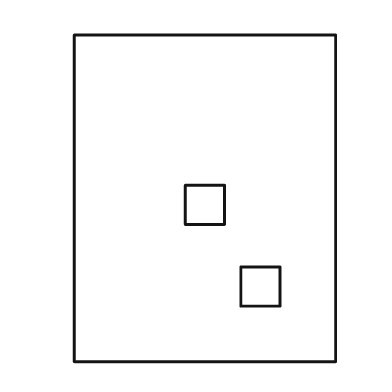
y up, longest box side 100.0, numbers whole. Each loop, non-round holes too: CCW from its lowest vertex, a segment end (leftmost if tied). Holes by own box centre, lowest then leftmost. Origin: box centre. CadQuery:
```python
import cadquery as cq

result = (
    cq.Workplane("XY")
    .moveTo(-40.0, -50.0)
    .lineTo(40.0, -50.0)
    .lineTo(40.0, 50.0)
    .lineTo(-40.0, 50.0)
    .close()
    .moveTo(11.0, -33.0)
    .lineTo(23.0, -33.0)
    .lineTo(23.0, -21.0)
    .lineTo(11.0, -21.0)
    .close()
    .moveTo(-6.0, -8.0)
    .lineTo(6.0, -8.0)
    .lineTo(6.0, 4.0)
    .lineTo(-6.0, 4.0)
    .close()
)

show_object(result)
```